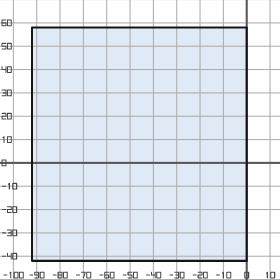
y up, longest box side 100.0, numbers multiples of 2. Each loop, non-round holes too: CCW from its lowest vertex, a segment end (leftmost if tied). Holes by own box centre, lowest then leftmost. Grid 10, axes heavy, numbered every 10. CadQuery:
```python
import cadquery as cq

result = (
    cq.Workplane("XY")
    .moveTo(-92.0, -42.0)
    .lineTo(0.0, -42.0)
    .lineTo(0.0, 58.0)
    .lineTo(-92.0, 58.0)
    .close()
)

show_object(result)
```